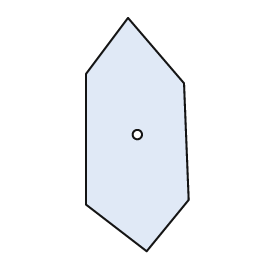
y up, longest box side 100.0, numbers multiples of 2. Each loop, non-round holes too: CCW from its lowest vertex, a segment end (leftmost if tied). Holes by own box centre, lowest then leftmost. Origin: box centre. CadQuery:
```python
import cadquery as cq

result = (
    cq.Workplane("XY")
    .moveTo(4.0, -50.0)
    .lineTo(22.0, -28.0)
    .lineTo(20.0, 22.0)
    .lineTo(-4.0, 50.0)
    .lineTo(-22.0, 26.0)
    .lineTo(-22.0, -30.0)
    .close()
    .moveTo(0.0, 0.0)
    .circle(2.0)
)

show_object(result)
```